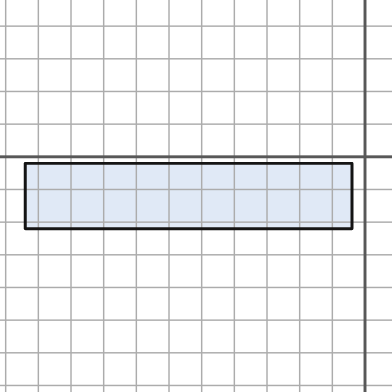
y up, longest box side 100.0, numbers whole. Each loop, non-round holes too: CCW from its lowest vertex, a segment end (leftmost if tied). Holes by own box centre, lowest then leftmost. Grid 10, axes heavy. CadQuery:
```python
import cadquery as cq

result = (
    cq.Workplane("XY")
    .moveTo(-104.0, -22.0)
    .lineTo(-4.0, -22.0)
    .lineTo(-4.0, -2.0)
    .lineTo(-104.0, -2.0)
    .close()
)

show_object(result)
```